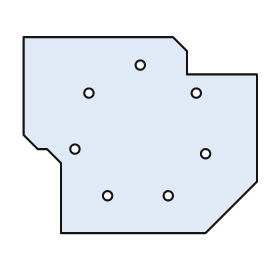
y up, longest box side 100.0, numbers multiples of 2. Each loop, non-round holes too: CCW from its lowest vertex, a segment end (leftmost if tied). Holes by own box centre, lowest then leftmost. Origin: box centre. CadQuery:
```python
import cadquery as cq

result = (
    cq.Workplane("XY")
    .moveTo(-34.0, -42.0)
    .lineTo(28.0, -42.0)
    .lineTo(50.0, -20.0)
    .lineTo(50.0, 26.0)
    .lineTo(20.0, 26.0)
    .lineTo(20.0, 36.0)
    .lineTo(14.0, 42.0)
    .lineTo(-50.0, 42.0)
    .lineTo(-50.0, 0.0)
    .lineTo(-44.0, -6.0)
    .lineTo(-40.0, -6.0)
    .lineTo(-34.0, -12.0)
    .close()
    .moveTo(-14.0, -26.0)
    .circle(2.0)
    .moveTo(12.0, -26.0)
    .circle(2.0)
    .moveTo(28.0, -8.0)
    .circle(2.0)
    .moveTo(-28.0, -6.0)
    .circle(2.0)
    .moveTo(-22.0, 18.0)
    .circle(2.0)
    .moveTo(24.0, 18.0)
    .circle(2.0)
    .moveTo(0.0, 30.0)
    .circle(2.0)
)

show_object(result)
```